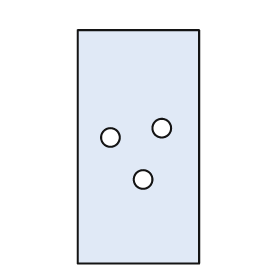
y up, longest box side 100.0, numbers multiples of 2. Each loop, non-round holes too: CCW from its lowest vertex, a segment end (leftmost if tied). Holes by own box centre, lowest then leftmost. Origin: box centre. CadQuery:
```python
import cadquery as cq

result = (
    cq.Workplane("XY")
    .moveTo(-26.0, -50.0)
    .lineTo(26.0, -50.0)
    .lineTo(26.0, 50.0)
    .lineTo(-26.0, 50.0)
    .close()
    .moveTo(2.0, -14.0)
    .circle(4.0)
    .moveTo(-12.0, 4.0)
    .circle(4.0)
    .moveTo(10.0, 8.0)
    .circle(4.0)
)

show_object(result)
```